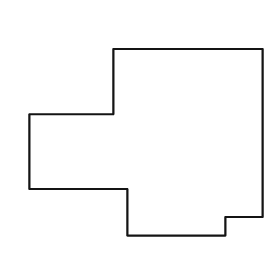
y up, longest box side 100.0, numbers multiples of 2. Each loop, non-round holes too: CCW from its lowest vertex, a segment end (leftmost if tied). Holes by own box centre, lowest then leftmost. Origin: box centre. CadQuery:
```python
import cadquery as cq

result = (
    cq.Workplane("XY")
    .moveTo(-8.0, -40.0)
    .lineTo(34.0, -40.0)
    .lineTo(34.0, -32.0)
    .lineTo(50.0, -32.0)
    .lineTo(50.0, 40.0)
    .lineTo(-14.0, 40.0)
    .lineTo(-14.0, 12.0)
    .lineTo(-50.0, 12.0)
    .lineTo(-50.0, -20.0)
    .lineTo(-8.0, -20.0)
    .close()
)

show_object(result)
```